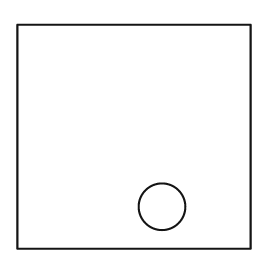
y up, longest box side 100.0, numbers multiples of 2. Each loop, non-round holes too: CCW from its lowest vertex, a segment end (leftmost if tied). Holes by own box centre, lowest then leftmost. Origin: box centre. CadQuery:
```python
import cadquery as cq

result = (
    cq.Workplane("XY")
    .moveTo(-50.0, -48.0)
    .lineTo(50.0, -48.0)
    .lineTo(50.0, 48.0)
    .lineTo(-50.0, 48.0)
    .close()
    .moveTo(12.0, -30.0)
    .circle(10.0)
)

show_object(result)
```